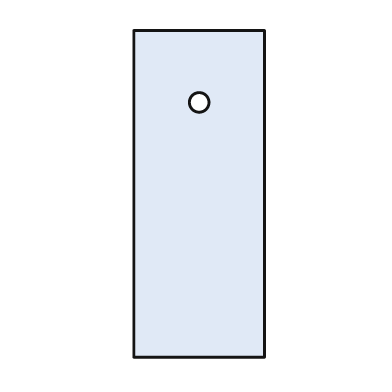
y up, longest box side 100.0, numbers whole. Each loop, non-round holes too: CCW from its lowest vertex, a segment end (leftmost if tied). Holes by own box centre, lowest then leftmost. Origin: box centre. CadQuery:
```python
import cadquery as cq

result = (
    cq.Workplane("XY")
    .moveTo(-20.0, -50.0)
    .lineTo(20.0, -50.0)
    .lineTo(20.0, 50.0)
    .lineTo(-20.0, 50.0)
    .close()
    .moveTo(0.0, 28.0)
    .circle(3.0)
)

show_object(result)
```